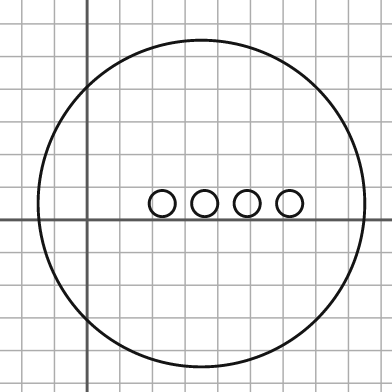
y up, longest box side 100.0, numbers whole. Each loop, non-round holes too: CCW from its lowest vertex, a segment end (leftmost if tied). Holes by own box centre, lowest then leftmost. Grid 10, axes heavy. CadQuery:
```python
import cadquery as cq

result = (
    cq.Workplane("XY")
    .moveTo(35.0, 5.0)
    .circle(50.0)
    .moveTo(23.0, 5.0)
    .circle(4.0)
    .moveTo(36.0, 5.0)
    .circle(4.0)
    .moveTo(49.0, 5.0)
    .circle(4.0)
    .moveTo(62.0, 5.0)
    .circle(4.0)
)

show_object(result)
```